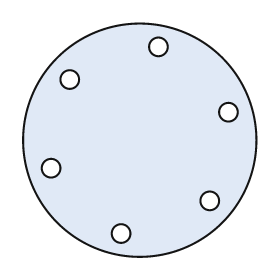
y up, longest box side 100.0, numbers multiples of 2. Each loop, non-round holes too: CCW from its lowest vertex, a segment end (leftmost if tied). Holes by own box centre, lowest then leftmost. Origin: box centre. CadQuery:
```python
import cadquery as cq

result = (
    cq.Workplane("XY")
    .moveTo(0.0, 0.0)
    .circle(50.0)
    .moveTo(-8.0, -40.0)
    .circle(4.0)
    .moveTo(30.0, -26.0)
    .circle(4.0)
    .moveTo(-38.0, -12.0)
    .circle(4.0)
    .moveTo(38.0, 12.0)
    .circle(4.0)
    .moveTo(-30.0, 26.0)
    .circle(4.0)
    .moveTo(8.0, 40.0)
    .circle(4.0)
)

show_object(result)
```